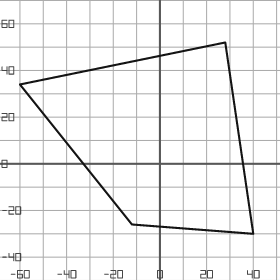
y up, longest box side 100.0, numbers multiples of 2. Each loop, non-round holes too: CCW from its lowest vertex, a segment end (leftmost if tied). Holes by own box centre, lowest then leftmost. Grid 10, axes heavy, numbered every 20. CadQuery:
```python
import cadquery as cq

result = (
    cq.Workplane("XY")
    .moveTo(40.0, -30.0)
    .lineTo(28.0, 52.0)
    .lineTo(-60.0, 34.0)
    .lineTo(-12.0, -26.0)
    .close()
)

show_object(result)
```